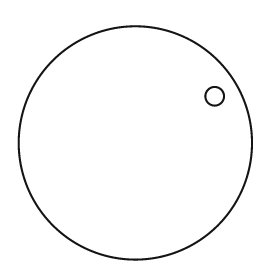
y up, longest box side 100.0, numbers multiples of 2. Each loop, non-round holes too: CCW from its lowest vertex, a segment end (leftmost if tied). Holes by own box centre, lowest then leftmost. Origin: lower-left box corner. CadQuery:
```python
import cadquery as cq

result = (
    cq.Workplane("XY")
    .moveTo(50.0, 50.0)
    .circle(50.0)
    .moveTo(84.0, 70.0)
    .circle(4.0)
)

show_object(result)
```